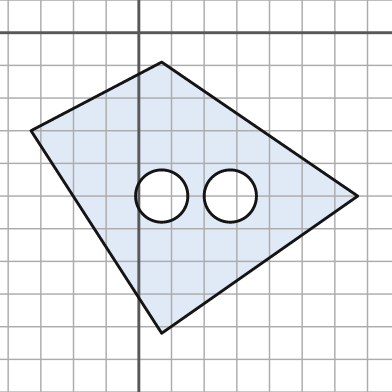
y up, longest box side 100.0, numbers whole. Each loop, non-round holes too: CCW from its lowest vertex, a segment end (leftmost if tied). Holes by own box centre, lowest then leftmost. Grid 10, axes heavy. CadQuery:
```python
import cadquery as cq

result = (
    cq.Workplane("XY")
    .moveTo(7.0, -92.0)
    .lineTo(67.0, -50.0)
    .lineTo(7.0, -9.0)
    .lineTo(-33.0, -30.0)
    .close()
    .moveTo(7.0, -50.0)
    .circle(8.0)
    .moveTo(28.0, -50.0)
    .circle(8.0)
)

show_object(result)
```